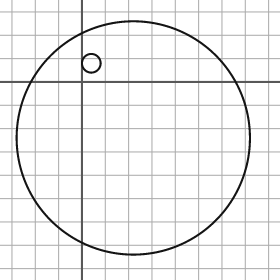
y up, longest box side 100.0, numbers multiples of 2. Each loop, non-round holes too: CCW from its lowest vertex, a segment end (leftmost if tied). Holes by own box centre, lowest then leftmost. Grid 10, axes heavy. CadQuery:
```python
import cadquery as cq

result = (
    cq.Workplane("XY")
    .moveTo(22.0, -24.0)
    .circle(50.0)
    .moveTo(4.0, 8.0)
    .circle(4.0)
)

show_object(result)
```